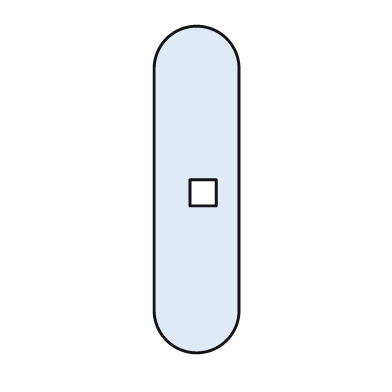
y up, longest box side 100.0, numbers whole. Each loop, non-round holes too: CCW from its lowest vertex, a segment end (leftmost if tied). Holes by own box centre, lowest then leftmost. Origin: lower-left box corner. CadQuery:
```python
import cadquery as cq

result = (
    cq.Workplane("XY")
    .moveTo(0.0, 13.0)
    .threePointArc((13.0, 0.0), (26.0, 13.0))
    .lineTo(26.0, 87.0)
    .threePointArc((13.0, 100.0), (0.0, 87.0))
    .close()
    .moveTo(11.0, 45.0)
    .lineTo(19.0, 45.0)
    .lineTo(19.0, 53.0)
    .lineTo(11.0, 53.0)
    .close()
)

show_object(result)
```